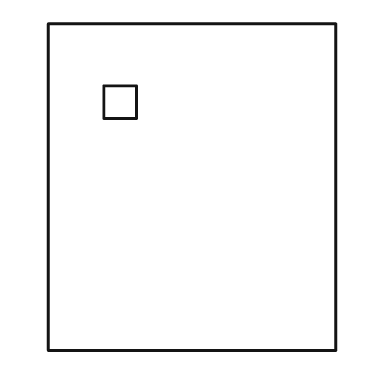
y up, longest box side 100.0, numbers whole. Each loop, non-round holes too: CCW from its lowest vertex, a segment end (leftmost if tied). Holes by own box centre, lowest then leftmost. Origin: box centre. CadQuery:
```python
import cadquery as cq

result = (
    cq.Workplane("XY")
    .moveTo(-44.0, -50.0)
    .lineTo(44.0, -50.0)
    .lineTo(44.0, 50.0)
    .lineTo(-44.0, 50.0)
    .close()
    .moveTo(-27.0, 21.0)
    .lineTo(-17.0, 21.0)
    .lineTo(-17.0, 31.0)
    .lineTo(-27.0, 31.0)
    .close()
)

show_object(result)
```